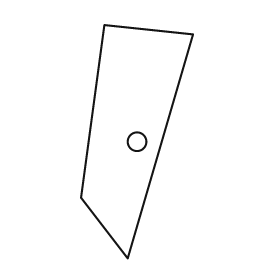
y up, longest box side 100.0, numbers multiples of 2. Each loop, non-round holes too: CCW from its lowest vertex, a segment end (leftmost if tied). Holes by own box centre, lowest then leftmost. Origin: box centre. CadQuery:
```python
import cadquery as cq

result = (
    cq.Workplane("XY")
    .moveTo(-4.0, -50.0)
    .lineTo(24.0, 46.0)
    .lineTo(-14.0, 50.0)
    .lineTo(-24.0, -24.0)
    .close()
    .moveTo(0.0, 0.0)
    .circle(4.0)
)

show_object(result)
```